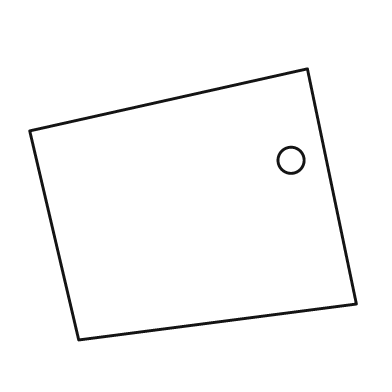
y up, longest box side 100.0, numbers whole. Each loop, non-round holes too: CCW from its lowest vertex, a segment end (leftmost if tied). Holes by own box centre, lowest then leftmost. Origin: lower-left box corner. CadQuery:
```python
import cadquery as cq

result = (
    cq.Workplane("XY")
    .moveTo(15.0, 0.0)
    .lineTo(100.0, 11.0)
    .lineTo(85.0, 83.0)
    .lineTo(0.0, 64.0)
    .close()
    .moveTo(80.0, 55.0)
    .circle(4.0)
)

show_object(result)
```